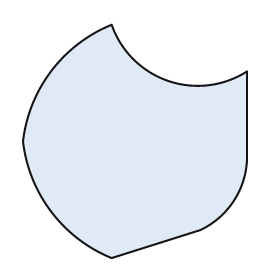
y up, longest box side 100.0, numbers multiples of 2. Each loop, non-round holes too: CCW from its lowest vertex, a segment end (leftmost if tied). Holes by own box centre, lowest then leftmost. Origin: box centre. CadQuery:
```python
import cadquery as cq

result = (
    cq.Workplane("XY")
    .moveTo(-10.0, -50.0)
    .lineTo(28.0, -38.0)
    .threePointArc((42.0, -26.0), (48.0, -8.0))
    .lineTo(48.0, 30.0)
    .threePointArc((14.0, 26.0), (-10.0, 50.0))
    .threePointArc((-36.0, 30.0), (-48.0, 0.0))
    .threePointArc((-36.0, -30.0), (-10.0, -50.0))
    .close()
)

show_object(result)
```